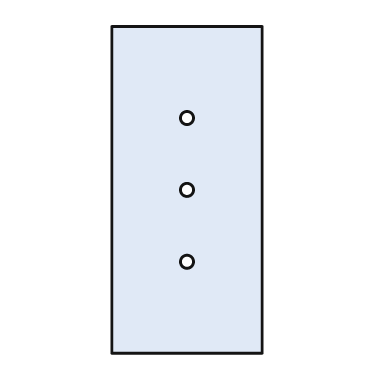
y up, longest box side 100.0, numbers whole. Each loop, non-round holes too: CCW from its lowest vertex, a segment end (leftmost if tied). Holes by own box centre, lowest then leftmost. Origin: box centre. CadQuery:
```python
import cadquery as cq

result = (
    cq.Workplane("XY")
    .moveTo(-23.0, -50.0)
    .lineTo(23.0, -50.0)
    .lineTo(23.0, 50.0)
    .lineTo(-23.0, 50.0)
    .close()
    .moveTo(0.0, -22.0)
    .circle(2.0)
    .moveTo(0.0, 0.0)
    .circle(2.0)
    .moveTo(0.0, 22.0)
    .circle(2.0)
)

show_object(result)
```